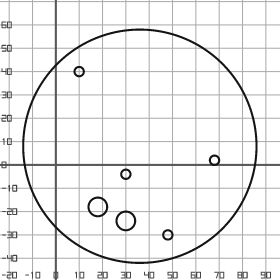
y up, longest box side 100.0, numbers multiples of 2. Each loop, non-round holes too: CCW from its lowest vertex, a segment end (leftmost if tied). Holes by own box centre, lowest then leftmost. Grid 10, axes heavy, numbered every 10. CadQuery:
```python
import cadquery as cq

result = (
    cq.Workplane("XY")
    .moveTo(36.0, 8.0)
    .circle(50.0)
    .moveTo(48.0, -30.0)
    .circle(2.0)
    .moveTo(30.0, -24.0)
    .circle(4.0)
    .moveTo(18.0, -18.0)
    .circle(4.0)
    .moveTo(30.0, -4.0)
    .circle(2.0)
    .moveTo(68.0, 2.0)
    .circle(2.0)
    .moveTo(10.0, 40.0)
    .circle(2.0)
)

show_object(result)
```